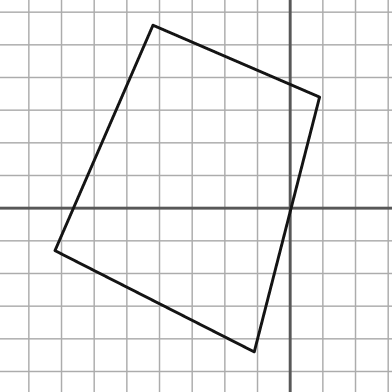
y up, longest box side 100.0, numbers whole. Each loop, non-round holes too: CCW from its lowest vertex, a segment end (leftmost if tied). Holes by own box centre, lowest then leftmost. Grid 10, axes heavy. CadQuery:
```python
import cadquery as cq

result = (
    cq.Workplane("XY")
    .moveTo(-11.0, -44.0)
    .lineTo(9.0, 34.0)
    .lineTo(-42.0, 56.0)
    .lineTo(-72.0, -13.0)
    .close()
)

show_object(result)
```